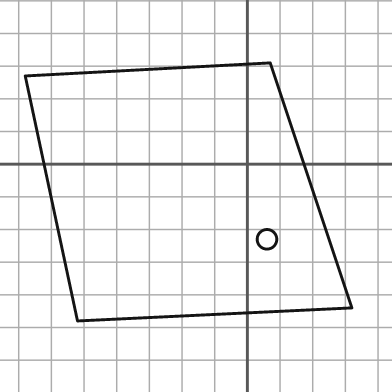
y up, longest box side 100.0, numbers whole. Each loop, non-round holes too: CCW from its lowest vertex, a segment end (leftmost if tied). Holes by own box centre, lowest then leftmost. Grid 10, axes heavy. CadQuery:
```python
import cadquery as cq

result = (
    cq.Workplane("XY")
    .moveTo(-52.0, -48.0)
    .lineTo(32.0, -44.0)
    .lineTo(7.0, 31.0)
    .lineTo(-68.0, 27.0)
    .close()
    .moveTo(6.0, -23.0)
    .circle(3.0)
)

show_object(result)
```